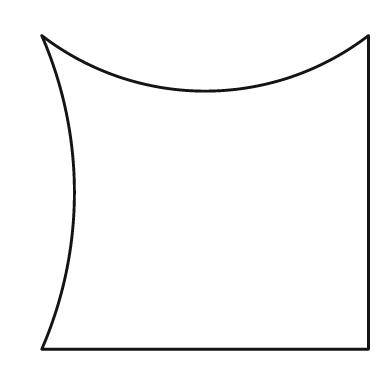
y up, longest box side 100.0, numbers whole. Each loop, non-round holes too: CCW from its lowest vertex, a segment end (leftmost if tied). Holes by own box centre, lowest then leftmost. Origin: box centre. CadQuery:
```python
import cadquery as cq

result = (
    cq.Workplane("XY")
    .moveTo(-50.0, -48.0)
    .lineTo(50.0, -48.0)
    .lineTo(50.0, 48.0)
    .threePointArc((0.0, 31.0), (-50.0, 48.0))
    .threePointArc((-40.0, 0.0), (-50.0, -48.0))
    .close()
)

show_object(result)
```